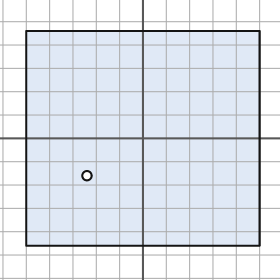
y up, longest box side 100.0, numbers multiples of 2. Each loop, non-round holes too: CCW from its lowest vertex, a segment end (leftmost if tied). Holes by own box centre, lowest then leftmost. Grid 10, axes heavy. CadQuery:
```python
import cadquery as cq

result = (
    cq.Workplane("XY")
    .moveTo(-50.0, -46.0)
    .lineTo(50.0, -46.0)
    .lineTo(50.0, 46.0)
    .lineTo(-50.0, 46.0)
    .close()
    .moveTo(-24.0, -16.0)
    .circle(2.0)
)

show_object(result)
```